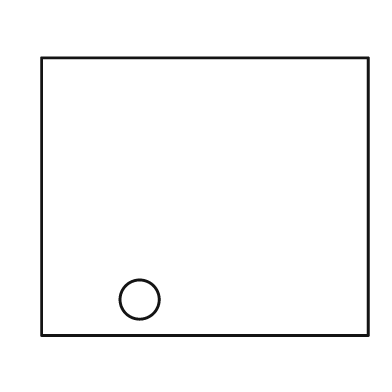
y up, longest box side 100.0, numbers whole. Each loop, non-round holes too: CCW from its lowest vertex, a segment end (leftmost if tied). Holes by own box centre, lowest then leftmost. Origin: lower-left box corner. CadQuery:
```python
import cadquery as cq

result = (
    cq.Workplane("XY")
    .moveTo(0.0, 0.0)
    .lineTo(100.0, 0.0)
    .lineTo(100.0, 85.0)
    .lineTo(0.0, 85.0)
    .close()
    .moveTo(30.0, 11.0)
    .circle(6.0)
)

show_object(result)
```